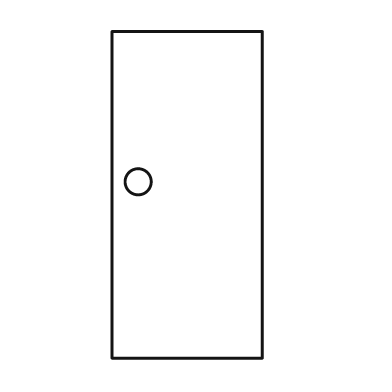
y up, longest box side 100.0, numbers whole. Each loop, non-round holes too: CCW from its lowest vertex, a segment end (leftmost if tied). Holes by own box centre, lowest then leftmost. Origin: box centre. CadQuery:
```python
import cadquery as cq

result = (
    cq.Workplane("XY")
    .moveTo(-23.0, -50.0)
    .lineTo(23.0, -50.0)
    .lineTo(23.0, 50.0)
    .lineTo(-23.0, 50.0)
    .close()
    .moveTo(-15.0, 4.0)
    .circle(4.0)
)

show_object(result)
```